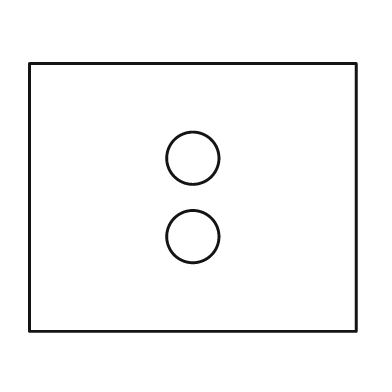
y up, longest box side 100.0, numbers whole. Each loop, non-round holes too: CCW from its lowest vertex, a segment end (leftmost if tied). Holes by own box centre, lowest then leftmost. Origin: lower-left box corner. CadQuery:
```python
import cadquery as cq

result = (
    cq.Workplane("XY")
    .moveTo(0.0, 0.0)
    .lineTo(100.0, 0.0)
    .lineTo(100.0, 82.0)
    .lineTo(0.0, 82.0)
    .close()
    .moveTo(50.0, 29.0)
    .circle(8.0)
    .moveTo(50.0, 53.0)
    .circle(8.0)
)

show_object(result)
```